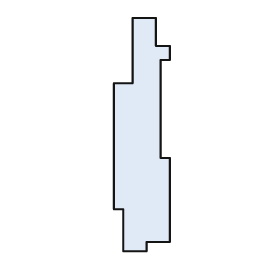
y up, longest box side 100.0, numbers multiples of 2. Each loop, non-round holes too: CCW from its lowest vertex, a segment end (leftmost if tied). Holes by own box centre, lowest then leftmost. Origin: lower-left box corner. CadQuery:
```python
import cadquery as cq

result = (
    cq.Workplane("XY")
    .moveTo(4.0, 0.0)
    .lineTo(14.0, 0.0)
    .lineTo(14.0, 4.0)
    .lineTo(24.0, 4.0)
    .lineTo(24.0, 40.0)
    .lineTo(20.0, 40.0)
    .lineTo(20.0, 82.0)
    .lineTo(24.0, 82.0)
    .lineTo(24.0, 88.0)
    .lineTo(18.0, 88.0)
    .lineTo(18.0, 100.0)
    .lineTo(8.0, 100.0)
    .lineTo(8.0, 72.0)
    .lineTo(0.0, 72.0)
    .lineTo(0.0, 18.0)
    .lineTo(4.0, 18.0)
    .close()
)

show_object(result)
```